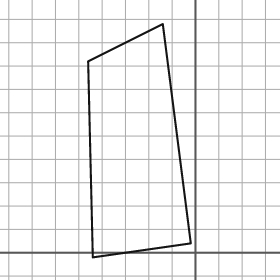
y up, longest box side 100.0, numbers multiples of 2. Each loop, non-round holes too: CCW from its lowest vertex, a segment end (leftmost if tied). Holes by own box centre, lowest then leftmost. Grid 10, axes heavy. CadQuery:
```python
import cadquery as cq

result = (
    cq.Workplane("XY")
    .moveTo(-44.0, -2.0)
    .lineTo(-2.0, 4.0)
    .lineTo(-14.0, 98.0)
    .lineTo(-46.0, 82.0)
    .close()
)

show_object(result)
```